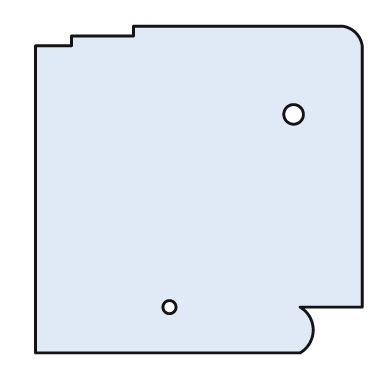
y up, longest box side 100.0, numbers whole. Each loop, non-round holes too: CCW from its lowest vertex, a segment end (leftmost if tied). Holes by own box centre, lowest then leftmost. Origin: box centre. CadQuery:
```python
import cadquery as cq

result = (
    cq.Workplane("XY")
    .moveTo(-50.0, -50.0)
    .lineTo(31.0, -50.0)
    .threePointArc((35.0, -43.0), (31.0, -36.0))
    .lineTo(50.0, -36.0)
    .lineTo(50.0, 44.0)
    .threePointArc((48.0, 48.0), (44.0, 50.0))
    .lineTo(-20.0, 50.0)
    .lineTo(-20.0, 47.0)
    .lineTo(-39.0, 47.0)
    .lineTo(-39.0, 44.0)
    .lineTo(-50.0, 44.0)
    .close()
    .moveTo(-9.0, -36.0)
    .circle(2.0)
    .moveTo(29.0, 23.0)
    .circle(3.0)
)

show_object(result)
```